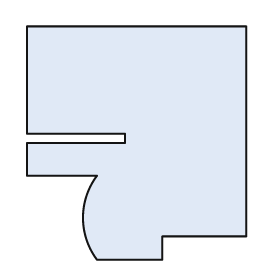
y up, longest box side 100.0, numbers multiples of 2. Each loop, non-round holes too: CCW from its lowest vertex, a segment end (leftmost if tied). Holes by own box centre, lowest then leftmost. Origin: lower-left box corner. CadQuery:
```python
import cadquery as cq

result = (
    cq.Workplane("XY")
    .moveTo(30.0, 0.0)
    .lineTo(58.0, 0.0)
    .lineTo(58.0, 10.0)
    .lineTo(94.0, 10.0)
    .lineTo(94.0, 100.0)
    .lineTo(0.0, 100.0)
    .lineTo(0.0, 54.0)
    .lineTo(42.0, 54.0)
    .lineTo(42.0, 50.0)
    .lineTo(0.0, 50.0)
    .lineTo(0.0, 36.0)
    .lineTo(30.0, 36.0)
    .threePointArc((24.0, 18.0), (30.0, 0.0))
    .close()
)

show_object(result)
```